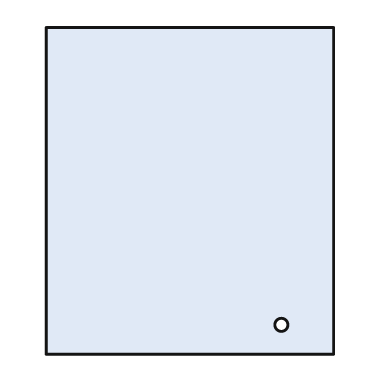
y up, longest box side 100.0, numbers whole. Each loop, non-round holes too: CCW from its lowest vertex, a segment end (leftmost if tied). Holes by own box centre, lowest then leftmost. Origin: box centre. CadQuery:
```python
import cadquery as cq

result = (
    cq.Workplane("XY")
    .moveTo(-44.0, -50.0)
    .lineTo(44.0, -50.0)
    .lineTo(44.0, 50.0)
    .lineTo(-44.0, 50.0)
    .close()
    .moveTo(28.0, -41.0)
    .circle(2.0)
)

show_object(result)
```